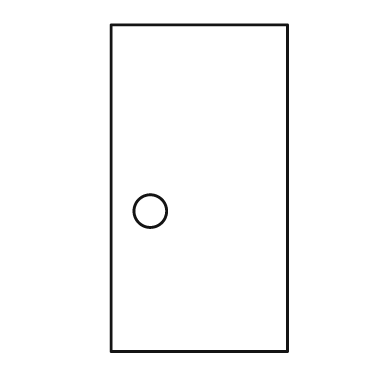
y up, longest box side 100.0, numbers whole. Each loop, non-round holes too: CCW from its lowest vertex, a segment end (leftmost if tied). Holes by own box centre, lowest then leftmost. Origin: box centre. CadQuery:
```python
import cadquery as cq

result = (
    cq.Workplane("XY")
    .moveTo(-27.0, -50.0)
    .lineTo(27.0, -50.0)
    .lineTo(27.0, 50.0)
    .lineTo(-27.0, 50.0)
    .close()
    .moveTo(-15.0, -7.0)
    .circle(5.0)
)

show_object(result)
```